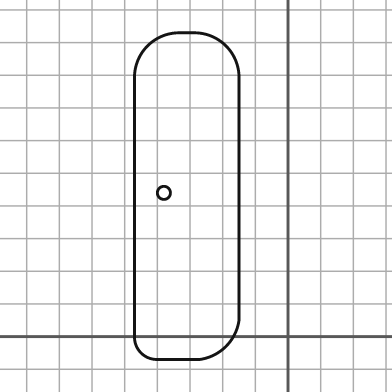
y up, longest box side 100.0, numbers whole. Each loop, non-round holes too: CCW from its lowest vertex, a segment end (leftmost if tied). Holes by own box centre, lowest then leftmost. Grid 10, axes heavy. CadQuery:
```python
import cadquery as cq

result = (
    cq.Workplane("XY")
    .moveTo(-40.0, -7.0)
    .lineTo(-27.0, -7.0)
    .threePointArc((-19.0, -3.0), (-15.0, 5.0))
    .lineTo(-15.0, 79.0)
    .threePointArc((-19.0, 89.0), (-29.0, 93.0))
    .lineTo(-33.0, 93.0)
    .threePointArc((-43.0, 89.0), (-47.0, 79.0))
    .lineTo(-47.0, 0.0)
    .threePointArc((-45.0, -5.0), (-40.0, -7.0))
    .close()
    .moveTo(-38.0, 44.0)
    .circle(2.0)
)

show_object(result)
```